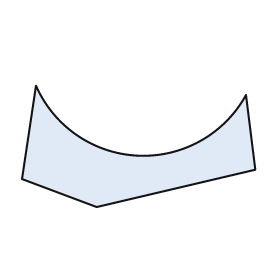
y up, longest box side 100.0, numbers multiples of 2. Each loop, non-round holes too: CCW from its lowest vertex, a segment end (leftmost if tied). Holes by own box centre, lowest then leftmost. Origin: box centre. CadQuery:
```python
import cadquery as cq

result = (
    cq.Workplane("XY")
    .moveTo(-18.0, -26.0)
    .lineTo(50.0, -10.0)
    .lineTo(46.0, 22.0)
    .threePointArc((0.0, -4.0), (-44.0, 26.0))
    .lineTo(-50.0, -14.0)
    .close()
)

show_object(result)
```